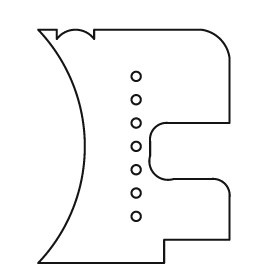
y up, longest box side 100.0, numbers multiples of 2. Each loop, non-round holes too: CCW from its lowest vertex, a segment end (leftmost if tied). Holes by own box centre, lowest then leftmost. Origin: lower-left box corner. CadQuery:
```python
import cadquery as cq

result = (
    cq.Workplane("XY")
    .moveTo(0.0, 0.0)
    .lineTo(54.0, 0.0)
    .lineTo(54.0, 10.0)
    .lineTo(82.0, 10.0)
    .lineTo(82.0, 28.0)
    .threePointArc((80.0, 34.0), (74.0, 36.0))
    .lineTo(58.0, 36.0)
    .threePointArc((50.0, 38.0), (48.0, 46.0))
    .lineTo(48.0, 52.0)
    .threePointArc((50.0, 58.0), (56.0, 60.0))
    .lineTo(82.0, 60.0)
    .lineTo(82.0, 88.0)
    .threePointArc((78.0, 96.0), (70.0, 100.0))
    .lineTo(24.0, 100.0)
    .lineTo(24.0, 96.0)
    .threePointArc((16.0, 100.0), (8.0, 96.0))
    .lineTo(8.0, 100.0)
    .lineTo(0.0, 100.0)
    .threePointArc((20.0, 50.0), (0.0, 0.0))
    .close()
    .moveTo(42.0, 20.0)
    .circle(2.0)
    .moveTo(42.0, 30.0)
    .circle(2.0)
    .moveTo(42.0, 40.0)
    .circle(2.0)
    .moveTo(42.0, 50.0)
    .circle(2.0)
    .moveTo(42.0, 60.0)
    .circle(2.0)
    .moveTo(42.0, 70.0)
    .circle(2.0)
    .moveTo(42.0, 80.0)
    .circle(2.0)
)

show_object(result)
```